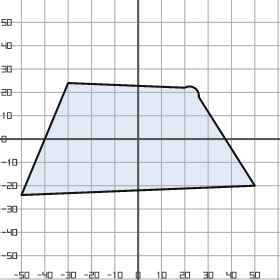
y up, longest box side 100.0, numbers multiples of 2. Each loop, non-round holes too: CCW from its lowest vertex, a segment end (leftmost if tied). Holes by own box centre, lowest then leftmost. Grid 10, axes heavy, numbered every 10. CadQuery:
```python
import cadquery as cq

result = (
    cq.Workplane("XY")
    .moveTo(-50.0, -24.0)
    .lineTo(50.0, -20.0)
    .lineTo(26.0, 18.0)
    .threePointArc((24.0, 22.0), (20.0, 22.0))
    .lineTo(-30.0, 24.0)
    .close()
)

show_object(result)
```